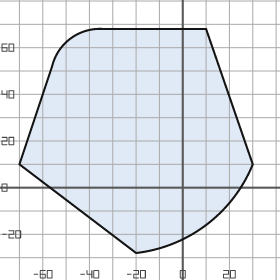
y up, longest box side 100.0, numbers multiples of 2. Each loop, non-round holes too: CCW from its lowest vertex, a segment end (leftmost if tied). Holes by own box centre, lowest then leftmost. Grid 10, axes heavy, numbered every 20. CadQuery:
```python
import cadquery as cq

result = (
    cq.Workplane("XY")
    .moveTo(-20.0, -28.0)
    .threePointArc((10.0, -16.0), (30.0, 10.0))
    .lineTo(10.0, 68.0)
    .lineTo(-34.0, 68.0)
    .threePointArc((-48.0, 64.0), (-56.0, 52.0))
    .lineTo(-70.0, 10.0)
    .close()
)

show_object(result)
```